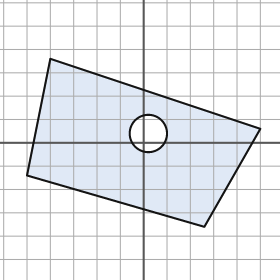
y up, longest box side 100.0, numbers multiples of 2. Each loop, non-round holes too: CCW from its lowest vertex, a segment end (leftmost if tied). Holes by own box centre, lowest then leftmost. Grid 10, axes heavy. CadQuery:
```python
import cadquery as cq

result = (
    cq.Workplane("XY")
    .moveTo(26.0, -36.0)
    .lineTo(50.0, 6.0)
    .lineTo(-40.0, 36.0)
    .lineTo(-50.0, -14.0)
    .close()
    .moveTo(2.0, 4.0)
    .circle(8.0)
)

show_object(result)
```